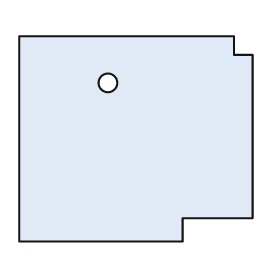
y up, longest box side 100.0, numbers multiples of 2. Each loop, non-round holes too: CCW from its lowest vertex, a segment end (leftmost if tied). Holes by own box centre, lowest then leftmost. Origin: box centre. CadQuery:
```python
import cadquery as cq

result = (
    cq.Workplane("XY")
    .moveTo(-50.0, -44.0)
    .lineTo(20.0, -44.0)
    .lineTo(20.0, -34.0)
    .lineTo(50.0, -34.0)
    .lineTo(50.0, 36.0)
    .lineTo(42.0, 36.0)
    .lineTo(42.0, 44.0)
    .lineTo(-50.0, 44.0)
    .close()
    .moveTo(-12.0, 24.0)
    .circle(4.0)
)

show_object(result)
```